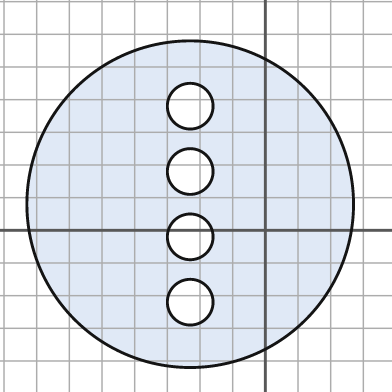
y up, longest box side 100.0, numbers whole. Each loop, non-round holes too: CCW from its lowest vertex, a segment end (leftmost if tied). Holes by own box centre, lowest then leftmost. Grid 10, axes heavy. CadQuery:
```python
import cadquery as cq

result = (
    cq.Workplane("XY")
    .moveTo(-23.0, 8.0)
    .circle(50.0)
    .moveTo(-23.0, -22.0)
    .circle(7.0)
    .moveTo(-23.0, -2.0)
    .circle(7.0)
    .moveTo(-23.0, 18.0)
    .circle(7.0)
    .moveTo(-23.0, 38.0)
    .circle(7.0)
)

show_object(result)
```